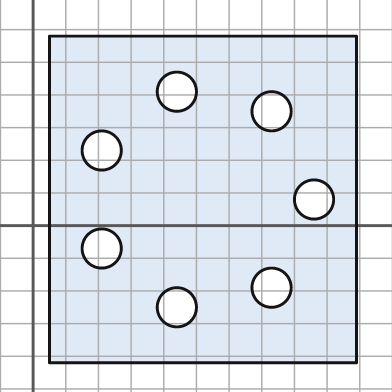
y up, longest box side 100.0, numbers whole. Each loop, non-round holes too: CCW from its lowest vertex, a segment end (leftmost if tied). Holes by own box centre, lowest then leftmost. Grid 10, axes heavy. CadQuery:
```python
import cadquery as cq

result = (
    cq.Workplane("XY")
    .moveTo(5.0, -42.0)
    .lineTo(99.0, -42.0)
    .lineTo(99.0, 58.0)
    .lineTo(5.0, 58.0)
    .close()
    .moveTo(44.0, -25.0)
    .circle(6.0)
    .moveTo(73.0, -19.0)
    .circle(6.0)
    .moveTo(21.0, -7.0)
    .circle(6.0)
    .moveTo(86.0, 8.0)
    .circle(6.0)
    .moveTo(21.0, 23.0)
    .circle(6.0)
    .moveTo(73.0, 35.0)
    .circle(6.0)
    .moveTo(44.0, 41.0)
    .circle(6.0)
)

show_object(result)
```